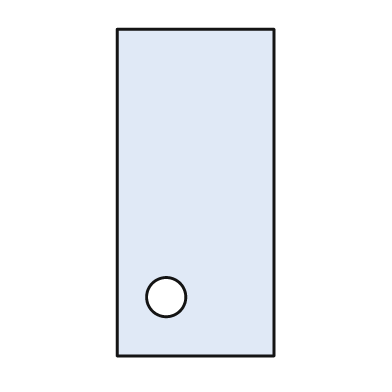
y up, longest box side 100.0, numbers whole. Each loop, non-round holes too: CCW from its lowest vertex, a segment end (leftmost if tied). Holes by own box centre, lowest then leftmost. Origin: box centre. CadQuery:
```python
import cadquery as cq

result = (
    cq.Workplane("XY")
    .moveTo(-24.0, -50.0)
    .lineTo(24.0, -50.0)
    .lineTo(24.0, 50.0)
    .lineTo(-24.0, 50.0)
    .close()
    .moveTo(-9.0, -32.0)
    .circle(6.0)
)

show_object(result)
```